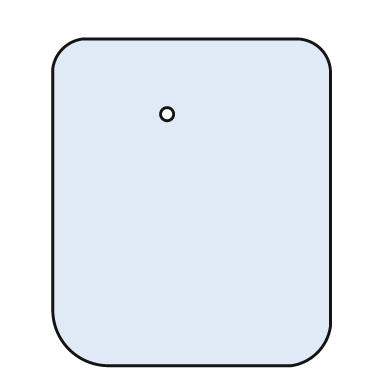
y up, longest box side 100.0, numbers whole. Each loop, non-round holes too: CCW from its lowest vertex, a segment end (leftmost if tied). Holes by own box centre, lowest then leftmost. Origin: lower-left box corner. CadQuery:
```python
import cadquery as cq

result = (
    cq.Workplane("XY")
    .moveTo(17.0, 0.0)
    .lineTo(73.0, 0.0)
    .threePointArc((81.0, 4.0), (85.0, 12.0))
    .lineTo(85.0, 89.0)
    .threePointArc((82.0, 97.0), (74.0, 100.0))
    .lineTo(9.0, 100.0)
    .threePointArc((3.0, 97.0), (0.0, 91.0))
    .lineTo(0.0, 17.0)
    .threePointArc((5.0, 5.0), (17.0, 0.0))
    .close()
    .moveTo(35.0, 77.0)
    .circle(2.0)
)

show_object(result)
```